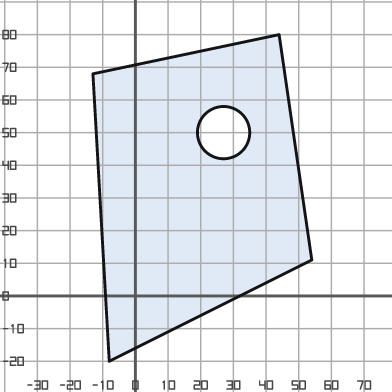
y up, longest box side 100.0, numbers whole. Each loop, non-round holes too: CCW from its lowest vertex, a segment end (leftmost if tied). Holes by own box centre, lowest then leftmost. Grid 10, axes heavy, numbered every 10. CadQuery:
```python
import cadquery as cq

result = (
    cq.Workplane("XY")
    .moveTo(-8.0, -20.0)
    .lineTo(54.0, 11.0)
    .lineTo(44.0, 80.0)
    .lineTo(-13.0, 68.0)
    .close()
    .moveTo(27.0, 50.0)
    .circle(8.0)
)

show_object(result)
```